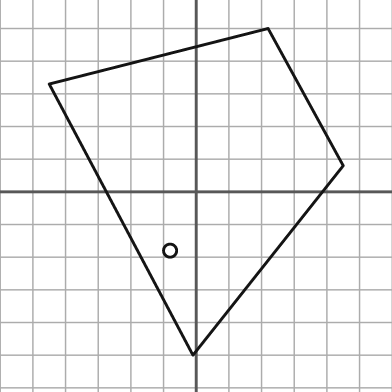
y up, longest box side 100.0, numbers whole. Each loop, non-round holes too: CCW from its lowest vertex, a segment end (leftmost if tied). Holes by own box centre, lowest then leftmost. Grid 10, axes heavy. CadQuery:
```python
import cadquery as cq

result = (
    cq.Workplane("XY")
    .moveTo(-1.0, -50.0)
    .lineTo(45.0, 8.0)
    .lineTo(22.0, 50.0)
    .lineTo(-45.0, 33.0)
    .close()
    .moveTo(-8.0, -18.0)
    .circle(2.0)
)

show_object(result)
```